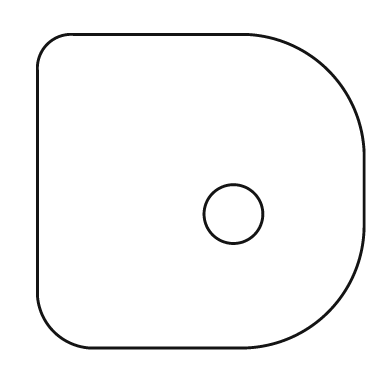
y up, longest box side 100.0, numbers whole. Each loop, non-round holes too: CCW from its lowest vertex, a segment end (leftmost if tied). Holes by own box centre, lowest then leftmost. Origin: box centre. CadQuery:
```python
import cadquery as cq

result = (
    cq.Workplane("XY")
    .moveTo(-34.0, -48.0)
    .lineTo(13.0, -48.0)
    .threePointArc((39.0, -37.0), (50.0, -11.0))
    .lineTo(50.0, 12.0)
    .threePointArc((39.0, 37.0), (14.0, 48.0))
    .lineTo(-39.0, 48.0)
    .threePointArc((-47.0, 45.0), (-50.0, 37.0))
    .lineTo(-50.0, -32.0)
    .threePointArc((-45.0, -43.0), (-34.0, -48.0))
    .close()
    .moveTo(10.0, -7.0)
    .circle(9.0)
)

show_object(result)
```